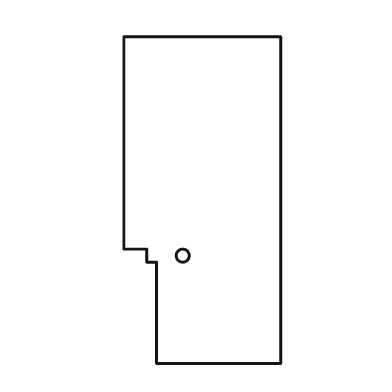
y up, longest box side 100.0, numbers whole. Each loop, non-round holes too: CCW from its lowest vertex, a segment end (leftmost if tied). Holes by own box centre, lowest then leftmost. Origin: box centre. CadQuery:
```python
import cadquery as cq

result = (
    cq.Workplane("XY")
    .moveTo(-14.0, -50.0)
    .lineTo(24.0, -50.0)
    .lineTo(24.0, 50.0)
    .lineTo(-24.0, 50.0)
    .lineTo(-24.0, -15.0)
    .lineTo(-17.0, -15.0)
    .lineTo(-17.0, -19.0)
    .lineTo(-14.0, -19.0)
    .close()
    .moveTo(-6.0, -17.0)
    .circle(2.0)
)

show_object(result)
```